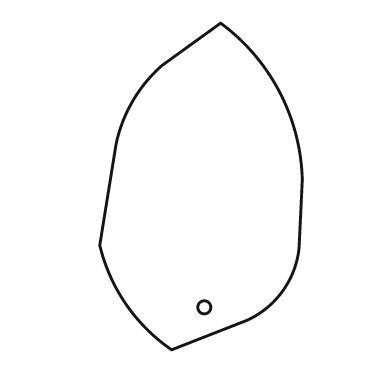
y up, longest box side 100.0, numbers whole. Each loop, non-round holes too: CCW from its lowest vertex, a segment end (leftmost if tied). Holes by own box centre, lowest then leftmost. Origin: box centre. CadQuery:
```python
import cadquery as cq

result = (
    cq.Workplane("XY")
    .moveTo(-9.0, -50.0)
    .lineTo(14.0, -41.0)
    .threePointArc((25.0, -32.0), (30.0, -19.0))
    .lineTo(31.0, 2.0)
    .threePointArc((24.0, 29.0), (6.0, 50.0))
    .lineTo(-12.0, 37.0)
    .threePointArc((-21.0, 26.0), (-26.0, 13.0))
    .lineTo(-31.0, -18.0)
    .threePointArc((-23.0, -36.0), (-9.0, -50.0))
    .close()
    .moveTo(1.0, -37.0)
    .circle(2.0)
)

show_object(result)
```